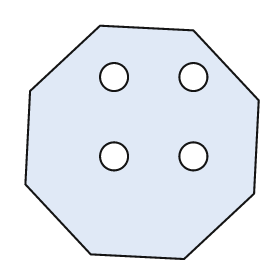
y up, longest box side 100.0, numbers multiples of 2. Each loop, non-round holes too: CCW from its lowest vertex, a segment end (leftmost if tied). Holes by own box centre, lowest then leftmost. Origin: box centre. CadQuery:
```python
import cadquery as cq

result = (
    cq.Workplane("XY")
    .moveTo(18.0, -50.0)
    .lineTo(48.0, -22.0)
    .lineTo(50.0, 18.0)
    .lineTo(22.0, 48.0)
    .lineTo(-18.0, 50.0)
    .lineTo(-48.0, 22.0)
    .lineTo(-50.0, -18.0)
    .lineTo(-22.0, -48.0)
    .close()
    .moveTo(-12.0, -6.0)
    .circle(6.0)
    .moveTo(22.0, -6.0)
    .circle(6.0)
    .moveTo(-12.0, 28.0)
    .circle(6.0)
    .moveTo(22.0, 28.0)
    .circle(6.0)
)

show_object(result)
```